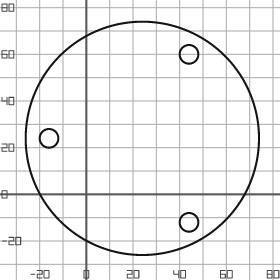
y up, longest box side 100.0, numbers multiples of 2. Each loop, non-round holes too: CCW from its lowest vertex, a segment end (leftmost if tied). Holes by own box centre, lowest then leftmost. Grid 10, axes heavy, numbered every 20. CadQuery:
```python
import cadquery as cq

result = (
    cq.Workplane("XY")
    .moveTo(24.0, 24.0)
    .circle(50.0)
    .moveTo(44.0, -12.0)
    .circle(4.0)
    .moveTo(-16.0, 24.0)
    .circle(4.0)
    .moveTo(44.0, 60.0)
    .circle(4.0)
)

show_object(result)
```